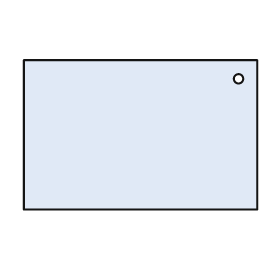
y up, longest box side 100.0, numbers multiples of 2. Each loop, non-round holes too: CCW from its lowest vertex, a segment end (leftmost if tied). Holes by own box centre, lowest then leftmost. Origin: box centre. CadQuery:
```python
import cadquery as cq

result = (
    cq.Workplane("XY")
    .moveTo(-50.0, -32.0)
    .lineTo(50.0, -32.0)
    .lineTo(50.0, 32.0)
    .lineTo(-50.0, 32.0)
    .close()
    .moveTo(42.0, 24.0)
    .circle(2.0)
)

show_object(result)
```